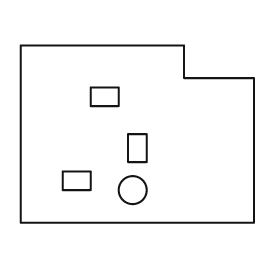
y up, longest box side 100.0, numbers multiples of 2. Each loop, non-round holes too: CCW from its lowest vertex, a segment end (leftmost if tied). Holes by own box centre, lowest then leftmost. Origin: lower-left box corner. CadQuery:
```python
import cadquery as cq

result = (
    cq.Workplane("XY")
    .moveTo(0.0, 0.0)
    .lineTo(100.0, 0.0)
    .lineTo(100.0, 62.0)
    .lineTo(70.0, 62.0)
    .lineTo(70.0, 76.0)
    .lineTo(0.0, 76.0)
    .close()
    .moveTo(48.0, 14.0)
    .circle(6.0)
    .moveTo(18.0, 14.0)
    .lineTo(30.0, 14.0)
    .lineTo(30.0, 22.0)
    .lineTo(18.0, 22.0)
    .close()
    .moveTo(46.0, 26.0)
    .lineTo(54.0, 26.0)
    .lineTo(54.0, 38.0)
    .lineTo(46.0, 38.0)
    .close()
    .moveTo(30.0, 50.0)
    .lineTo(42.0, 50.0)
    .lineTo(42.0, 58.0)
    .lineTo(30.0, 58.0)
    .close()
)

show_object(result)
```